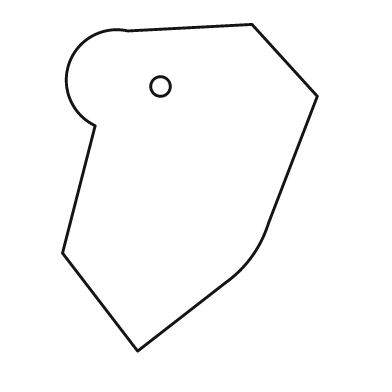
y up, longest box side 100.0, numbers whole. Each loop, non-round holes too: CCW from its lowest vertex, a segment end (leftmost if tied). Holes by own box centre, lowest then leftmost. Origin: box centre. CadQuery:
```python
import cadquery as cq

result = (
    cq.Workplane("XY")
    .moveTo(-16.0, -50.0)
    .lineTo(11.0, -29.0)
    .threePointArc((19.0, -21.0), (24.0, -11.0))
    .lineTo(39.0, 28.0)
    .lineTo(19.0, 50.0)
    .lineTo(-19.0, 48.0)
    .threePointArc((-37.0, 38.0), (-29.0, 19.0))
    .lineTo(-39.0, -20.0)
    .close()
    .moveTo(-9.0, 31.0)
    .circle(3.0)
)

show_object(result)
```